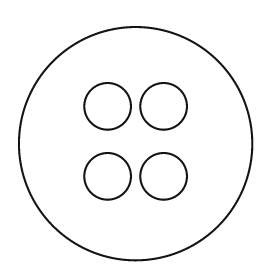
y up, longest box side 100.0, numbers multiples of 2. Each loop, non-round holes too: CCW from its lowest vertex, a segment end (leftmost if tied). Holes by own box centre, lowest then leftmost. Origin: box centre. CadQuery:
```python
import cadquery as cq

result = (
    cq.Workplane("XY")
    .moveTo(0.0, 0.0)
    .circle(50.0)
    .moveTo(-12.0, -14.0)
    .circle(10.0)
    .moveTo(12.0, -14.0)
    .circle(10.0)
    .moveTo(-12.0, 16.0)
    .circle(10.0)
    .moveTo(12.0, 16.0)
    .circle(10.0)
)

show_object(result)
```